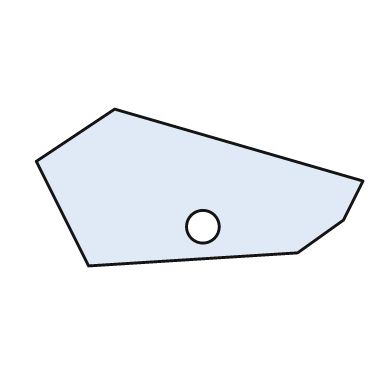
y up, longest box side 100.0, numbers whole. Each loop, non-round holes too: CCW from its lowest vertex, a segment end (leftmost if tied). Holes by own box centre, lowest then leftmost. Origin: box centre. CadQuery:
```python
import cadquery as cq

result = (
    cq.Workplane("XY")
    .moveTo(-34.0, -24.0)
    .lineTo(30.0, -20.0)
    .lineTo(44.0, -10.0)
    .lineTo(50.0, 2.0)
    .lineTo(-26.0, 24.0)
    .lineTo(-50.0, 8.0)
    .close()
    .moveTo(1.0, -12.0)
    .circle(5.0)
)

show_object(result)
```